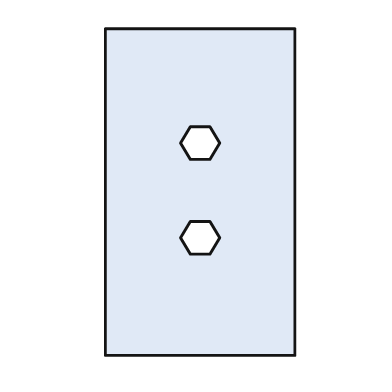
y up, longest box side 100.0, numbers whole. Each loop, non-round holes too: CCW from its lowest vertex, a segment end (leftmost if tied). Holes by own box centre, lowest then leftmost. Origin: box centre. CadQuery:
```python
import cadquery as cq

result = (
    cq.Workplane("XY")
    .moveTo(-29.0, -50.0)
    .lineTo(29.0, -50.0)
    .lineTo(29.0, 50.0)
    .lineTo(-29.0, 50.0)
    .close()
    .moveTo(-3.0, -19.0)
    .lineTo(3.0, -19.0)
    .lineTo(6.0, -14.0)
    .lineTo(3.0, -9.0)
    .lineTo(-3.0, -9.0)
    .lineTo(-6.0, -14.0)
    .close()
    .moveTo(-3.0, 10.0)
    .lineTo(3.0, 10.0)
    .lineTo(6.0, 15.0)
    .lineTo(3.0, 20.0)
    .lineTo(-3.0, 20.0)
    .lineTo(-6.0, 15.0)
    .close()
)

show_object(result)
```